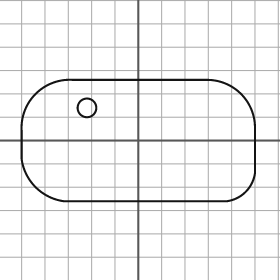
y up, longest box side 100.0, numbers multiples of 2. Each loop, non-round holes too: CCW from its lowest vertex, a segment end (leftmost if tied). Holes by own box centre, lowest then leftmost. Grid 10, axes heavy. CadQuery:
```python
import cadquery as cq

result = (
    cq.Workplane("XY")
    .moveTo(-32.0, -26.0)
    .lineTo(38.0, -26.0)
    .threePointArc((46.0, -22.0), (50.0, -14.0))
    .lineTo(50.0, 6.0)
    .threePointArc((44.0, 20.0), (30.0, 26.0))
    .lineTo(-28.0, 26.0)
    .threePointArc((-44.0, 20.0), (-50.0, 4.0))
    .lineTo(-50.0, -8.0)
    .threePointArc((-44.0, -20.0), (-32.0, -26.0))
    .close()
    .moveTo(-22.0, 14.0)
    .circle(4.0)
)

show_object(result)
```